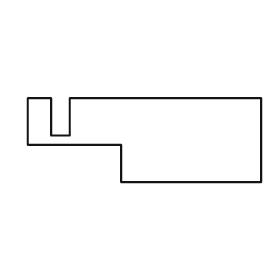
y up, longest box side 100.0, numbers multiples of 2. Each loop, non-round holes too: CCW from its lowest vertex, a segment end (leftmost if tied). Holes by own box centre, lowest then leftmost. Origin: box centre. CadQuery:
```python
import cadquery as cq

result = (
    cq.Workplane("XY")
    .moveTo(-10.0, -18.0)
    .lineTo(50.0, -18.0)
    .lineTo(50.0, 18.0)
    .lineTo(-32.0, 18.0)
    .lineTo(-32.0, 2.0)
    .lineTo(-40.0, 2.0)
    .lineTo(-40.0, 18.0)
    .lineTo(-50.0, 18.0)
    .lineTo(-50.0, -2.0)
    .lineTo(-10.0, -2.0)
    .close()
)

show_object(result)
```